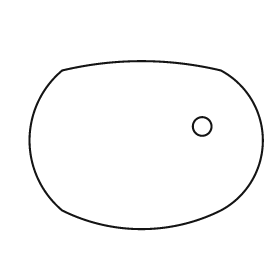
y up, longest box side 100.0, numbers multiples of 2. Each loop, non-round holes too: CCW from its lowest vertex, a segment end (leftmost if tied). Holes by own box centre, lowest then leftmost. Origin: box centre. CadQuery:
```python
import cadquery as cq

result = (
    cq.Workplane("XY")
    .moveTo(-36.0, -28.0)
    .threePointArc((-2.0, -36.0), (32.0, -28.0))
    .threePointArc((50.0, 2.0), (32.0, 32.0))
    .threePointArc((-2.0, 36.0), (-36.0, 32.0))
    .threePointArc((-50.0, 2.0), (-36.0, -28.0))
    .close()
    .moveTo(24.0, 8.0)
    .circle(4.0)
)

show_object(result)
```